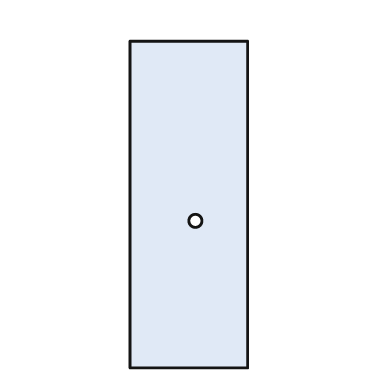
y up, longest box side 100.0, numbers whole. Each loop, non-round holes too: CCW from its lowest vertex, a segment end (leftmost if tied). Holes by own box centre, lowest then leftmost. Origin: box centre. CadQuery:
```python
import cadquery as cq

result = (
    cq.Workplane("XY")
    .moveTo(-18.0, -50.0)
    .lineTo(18.0, -50.0)
    .lineTo(18.0, 50.0)
    .lineTo(-18.0, 50.0)
    .close()
    .moveTo(2.0, -5.0)
    .circle(2.0)
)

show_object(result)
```